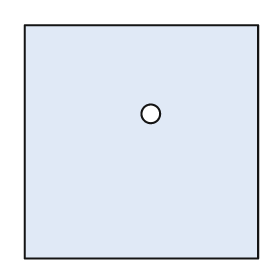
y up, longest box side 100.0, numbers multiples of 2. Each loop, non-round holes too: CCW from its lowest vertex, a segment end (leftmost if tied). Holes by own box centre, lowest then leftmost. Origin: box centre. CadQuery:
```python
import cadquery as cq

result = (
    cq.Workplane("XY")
    .moveTo(-50.0, -50.0)
    .lineTo(50.0, -50.0)
    .lineTo(50.0, 50.0)
    .lineTo(-50.0, 50.0)
    .close()
    .moveTo(4.0, 12.0)
    .circle(4.0)
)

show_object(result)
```